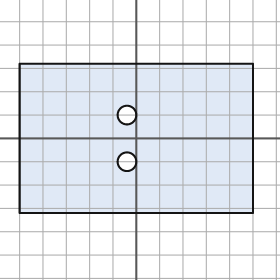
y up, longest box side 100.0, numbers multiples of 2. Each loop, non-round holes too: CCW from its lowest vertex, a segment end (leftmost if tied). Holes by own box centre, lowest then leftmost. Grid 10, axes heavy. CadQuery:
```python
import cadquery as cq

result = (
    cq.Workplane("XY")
    .moveTo(-50.0, -32.0)
    .lineTo(50.0, -32.0)
    .lineTo(50.0, 32.0)
    .lineTo(-50.0, 32.0)
    .close()
    .moveTo(-4.0, -10.0)
    .circle(4.0)
    .moveTo(-4.0, 10.0)
    .circle(4.0)
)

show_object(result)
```